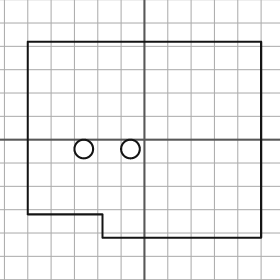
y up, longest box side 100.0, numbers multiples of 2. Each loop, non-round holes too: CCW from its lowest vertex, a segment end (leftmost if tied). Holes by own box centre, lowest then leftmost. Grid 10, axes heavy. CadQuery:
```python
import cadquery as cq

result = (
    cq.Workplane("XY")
    .moveTo(-18.0, -42.0)
    .lineTo(50.0, -42.0)
    .lineTo(50.0, 42.0)
    .lineTo(-50.0, 42.0)
    .lineTo(-50.0, -32.0)
    .lineTo(-18.0, -32.0)
    .close()
    .moveTo(-26.0, -4.0)
    .circle(4.0)
    .moveTo(-6.0, -4.0)
    .circle(4.0)
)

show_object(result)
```